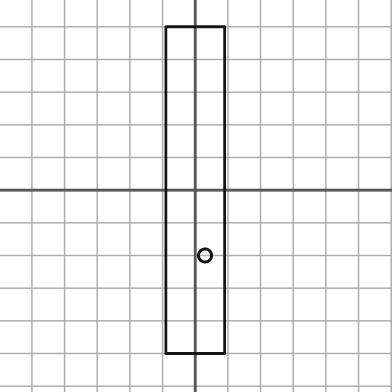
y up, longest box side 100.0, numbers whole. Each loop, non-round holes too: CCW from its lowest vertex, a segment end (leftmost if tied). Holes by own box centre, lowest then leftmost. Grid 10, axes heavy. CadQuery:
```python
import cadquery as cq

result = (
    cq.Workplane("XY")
    .moveTo(-9.0, -50.0)
    .lineTo(9.0, -50.0)
    .lineTo(9.0, 50.0)
    .lineTo(-9.0, 50.0)
    .close()
    .moveTo(3.0, -20.0)
    .circle(2.0)
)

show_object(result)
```